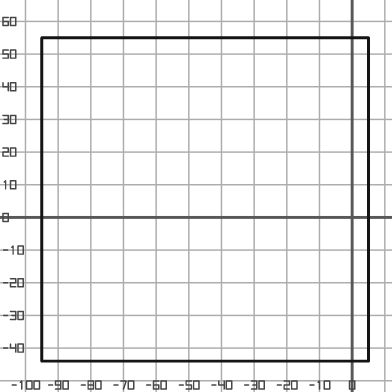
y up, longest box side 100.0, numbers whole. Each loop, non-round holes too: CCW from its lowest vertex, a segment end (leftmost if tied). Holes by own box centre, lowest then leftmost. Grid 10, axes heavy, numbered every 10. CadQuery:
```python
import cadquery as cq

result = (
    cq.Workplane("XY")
    .moveTo(-95.0, -44.0)
    .lineTo(5.0, -44.0)
    .lineTo(5.0, 55.0)
    .lineTo(-95.0, 55.0)
    .close()
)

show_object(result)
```